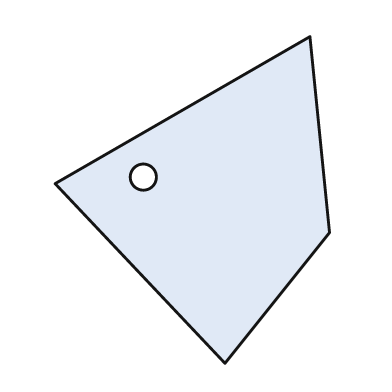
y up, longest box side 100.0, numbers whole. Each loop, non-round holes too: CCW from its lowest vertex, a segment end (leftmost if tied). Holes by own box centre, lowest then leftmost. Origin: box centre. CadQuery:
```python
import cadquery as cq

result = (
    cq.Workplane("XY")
    .moveTo(10.0, -50.0)
    .lineTo(42.0, -10.0)
    .lineTo(36.0, 50.0)
    .lineTo(-42.0, 5.0)
    .close()
    .moveTo(-15.0, 7.0)
    .circle(4.0)
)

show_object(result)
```